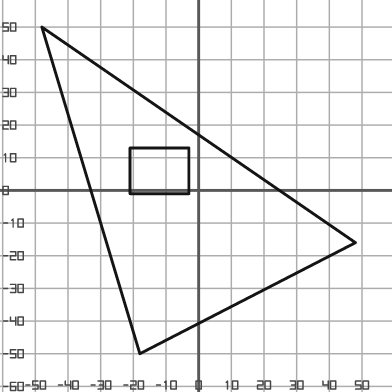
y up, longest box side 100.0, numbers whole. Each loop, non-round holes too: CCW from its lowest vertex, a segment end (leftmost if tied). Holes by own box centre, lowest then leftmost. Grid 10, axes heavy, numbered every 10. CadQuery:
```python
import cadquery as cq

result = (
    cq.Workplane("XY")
    .moveTo(-18.0, -50.0)
    .lineTo(48.0, -16.0)
    .lineTo(-48.0, 50.0)
    .close()
    .moveTo(-21.0, -1.0)
    .lineTo(-3.0, -1.0)
    .lineTo(-3.0, 13.0)
    .lineTo(-21.0, 13.0)
    .close()
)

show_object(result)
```